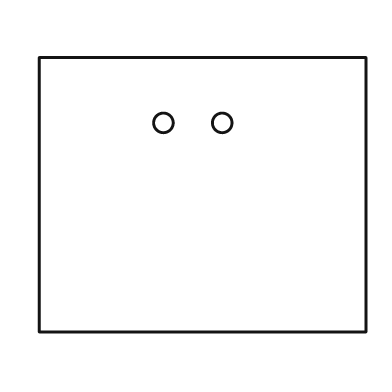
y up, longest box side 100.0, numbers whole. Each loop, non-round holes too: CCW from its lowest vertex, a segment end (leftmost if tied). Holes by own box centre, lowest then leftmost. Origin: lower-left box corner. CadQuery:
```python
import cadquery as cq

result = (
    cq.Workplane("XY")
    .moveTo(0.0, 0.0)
    .lineTo(100.0, 0.0)
    .lineTo(100.0, 84.0)
    .lineTo(0.0, 84.0)
    .close()
    .moveTo(38.0, 64.0)
    .circle(3.0)
    .moveTo(56.0, 64.0)
    .circle(3.0)
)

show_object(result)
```